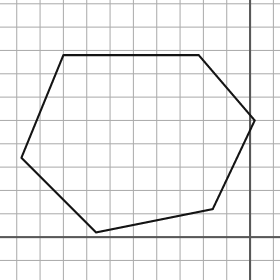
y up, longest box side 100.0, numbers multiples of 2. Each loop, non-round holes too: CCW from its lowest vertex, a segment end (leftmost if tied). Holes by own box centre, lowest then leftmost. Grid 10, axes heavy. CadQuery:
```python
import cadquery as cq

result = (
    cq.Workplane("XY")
    .moveTo(-66.0, 2.0)
    .lineTo(-16.0, 12.0)
    .lineTo(2.0, 50.0)
    .lineTo(-22.0, 78.0)
    .lineTo(-80.0, 78.0)
    .lineTo(-98.0, 34.0)
    .close()
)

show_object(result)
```